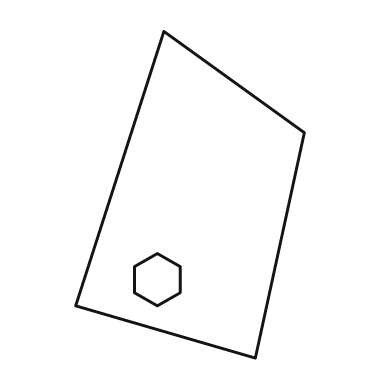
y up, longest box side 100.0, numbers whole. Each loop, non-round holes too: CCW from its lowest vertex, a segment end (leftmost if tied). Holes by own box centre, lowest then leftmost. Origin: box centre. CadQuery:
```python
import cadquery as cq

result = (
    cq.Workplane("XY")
    .moveTo(20.0, -50.0)
    .lineTo(35.0, 19.0)
    .lineTo(-8.0, 50.0)
    .lineTo(-35.0, -34.0)
    .close()
    .moveTo(-10.0, -34.0)
    .lineTo(-3.0, -30.0)
    .lineTo(-3.0, -22.0)
    .lineTo(-10.0, -18.0)
    .lineTo(-17.0, -22.0)
    .lineTo(-17.0, -30.0)
    .close()
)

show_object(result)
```